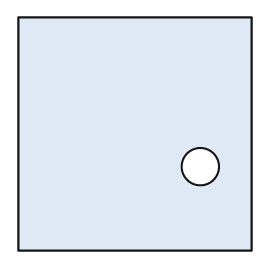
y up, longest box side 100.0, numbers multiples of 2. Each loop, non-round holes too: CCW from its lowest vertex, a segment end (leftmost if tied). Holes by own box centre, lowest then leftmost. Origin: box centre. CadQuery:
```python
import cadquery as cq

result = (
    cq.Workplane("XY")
    .moveTo(-50.0, -50.0)
    .lineTo(50.0, -50.0)
    .lineTo(50.0, 50.0)
    .lineTo(-50.0, 50.0)
    .close()
    .moveTo(28.0, -14.0)
    .circle(8.0)
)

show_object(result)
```